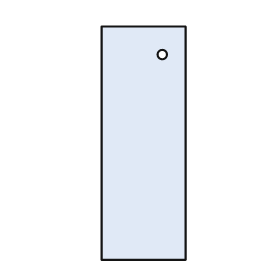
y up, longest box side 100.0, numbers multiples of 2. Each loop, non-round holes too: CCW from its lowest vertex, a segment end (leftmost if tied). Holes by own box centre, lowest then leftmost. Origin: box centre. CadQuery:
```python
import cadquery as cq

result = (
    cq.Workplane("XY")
    .moveTo(-18.0, -50.0)
    .lineTo(18.0, -50.0)
    .lineTo(18.0, 50.0)
    .lineTo(-18.0, 50.0)
    .close()
    .moveTo(8.0, 38.0)
    .circle(2.0)
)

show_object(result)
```